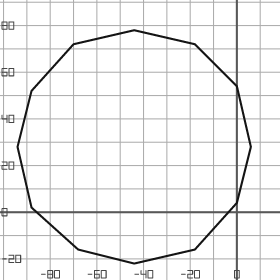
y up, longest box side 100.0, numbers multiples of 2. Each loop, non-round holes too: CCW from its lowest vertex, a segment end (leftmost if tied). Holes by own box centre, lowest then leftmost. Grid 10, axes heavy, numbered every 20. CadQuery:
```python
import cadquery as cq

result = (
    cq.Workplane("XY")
    .moveTo(-44.0, -22.0)
    .lineTo(-18.0, -16.0)
    .lineTo(0.0, 4.0)
    .lineTo(6.0, 28.0)
    .lineTo(0.0, 54.0)
    .lineTo(-18.0, 72.0)
    .lineTo(-44.0, 78.0)
    .lineTo(-70.0, 72.0)
    .lineTo(-88.0, 52.0)
    .lineTo(-94.0, 28.0)
    .lineTo(-88.0, 2.0)
    .lineTo(-68.0, -16.0)
    .close()
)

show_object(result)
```